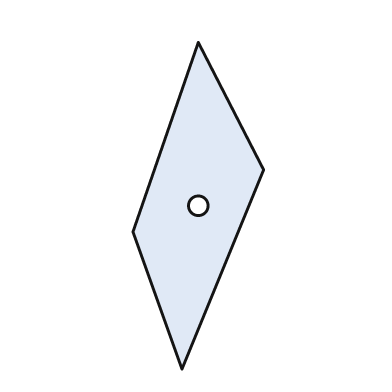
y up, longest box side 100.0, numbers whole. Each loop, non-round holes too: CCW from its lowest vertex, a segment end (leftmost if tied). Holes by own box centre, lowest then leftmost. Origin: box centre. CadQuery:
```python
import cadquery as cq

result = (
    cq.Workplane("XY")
    .moveTo(-5.0, -50.0)
    .lineTo(20.0, 11.0)
    .lineTo(0.0, 50.0)
    .lineTo(-20.0, -8.0)
    .close()
    .moveTo(0.0, 0.0)
    .circle(3.0)
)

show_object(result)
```